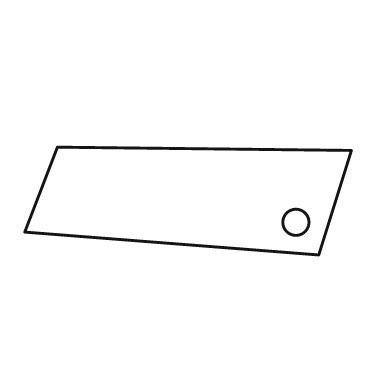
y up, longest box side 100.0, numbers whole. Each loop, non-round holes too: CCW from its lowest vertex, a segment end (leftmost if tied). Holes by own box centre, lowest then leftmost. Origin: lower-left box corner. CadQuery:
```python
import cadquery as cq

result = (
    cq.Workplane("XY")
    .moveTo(90.0, 0.0)
    .lineTo(100.0, 32.0)
    .lineTo(10.0, 33.0)
    .lineTo(0.0, 7.0)
    .close()
    .moveTo(83.0, 10.0)
    .circle(4.0)
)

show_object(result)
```